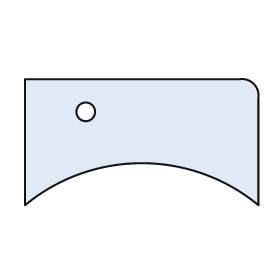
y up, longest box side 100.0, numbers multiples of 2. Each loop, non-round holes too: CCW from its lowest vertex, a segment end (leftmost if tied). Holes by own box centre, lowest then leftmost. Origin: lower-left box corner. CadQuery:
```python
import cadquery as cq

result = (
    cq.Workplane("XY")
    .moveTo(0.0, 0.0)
    .threePointArc((50.0, 18.0), (100.0, 0.0))
    .lineTo(100.0, 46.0)
    .threePointArc((98.0, 52.0), (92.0, 54.0))
    .lineTo(0.0, 54.0)
    .close()
    .moveTo(26.0, 40.0)
    .circle(4.0)
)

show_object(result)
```